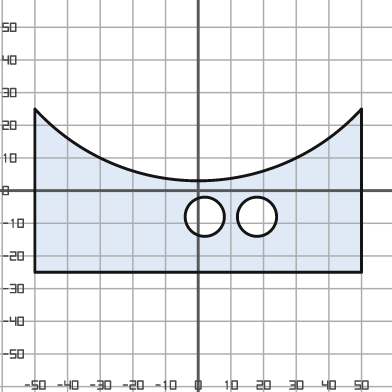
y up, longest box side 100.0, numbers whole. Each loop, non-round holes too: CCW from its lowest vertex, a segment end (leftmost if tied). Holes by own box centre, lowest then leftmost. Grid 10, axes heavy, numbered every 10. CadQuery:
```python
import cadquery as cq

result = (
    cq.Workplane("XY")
    .moveTo(-50.0, -25.0)
    .lineTo(50.0, -25.0)
    .lineTo(50.0, 25.0)
    .threePointArc((0.0, 3.0), (-50.0, 25.0))
    .close()
    .moveTo(2.0, -8.0)
    .circle(6.0)
    .moveTo(18.0, -8.0)
    .circle(6.0)
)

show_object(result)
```